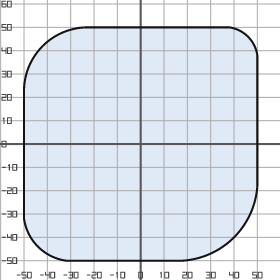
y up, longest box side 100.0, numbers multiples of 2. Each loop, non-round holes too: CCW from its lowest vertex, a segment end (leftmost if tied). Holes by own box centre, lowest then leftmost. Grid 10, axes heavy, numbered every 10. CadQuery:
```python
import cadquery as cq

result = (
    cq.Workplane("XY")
    .moveTo(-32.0, -50.0)
    .lineTo(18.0, -50.0)
    .threePointArc((40.0, -40.0), (50.0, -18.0))
    .lineTo(50.0, 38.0)
    .threePointArc((46.0, 46.0), (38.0, 50.0))
    .lineTo(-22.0, 50.0)
    .threePointArc((-42.0, 42.0), (-50.0, 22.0))
    .lineTo(-50.0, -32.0)
    .threePointArc((-44.0, -44.0), (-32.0, -50.0))
    .close()
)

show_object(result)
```